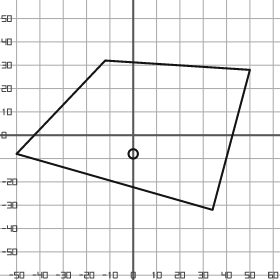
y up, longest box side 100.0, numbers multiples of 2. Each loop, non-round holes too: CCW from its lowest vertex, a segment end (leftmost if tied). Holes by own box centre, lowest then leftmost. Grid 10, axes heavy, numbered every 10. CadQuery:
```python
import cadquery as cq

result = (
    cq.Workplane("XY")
    .moveTo(34.0, -32.0)
    .lineTo(50.0, 28.0)
    .lineTo(-12.0, 32.0)
    .lineTo(-50.0, -8.0)
    .close()
    .moveTo(0.0, -8.0)
    .circle(2.0)
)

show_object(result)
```